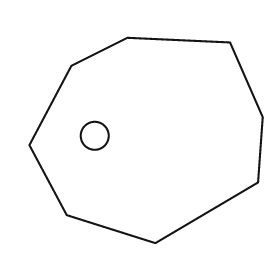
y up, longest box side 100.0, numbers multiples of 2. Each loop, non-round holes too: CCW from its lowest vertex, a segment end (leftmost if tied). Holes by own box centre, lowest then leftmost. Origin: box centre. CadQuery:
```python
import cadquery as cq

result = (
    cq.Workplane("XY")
    .moveTo(4.0, -44.0)
    .lineTo(48.0, -18.0)
    .lineTo(50.0, 10.0)
    .lineTo(36.0, 42.0)
    .lineTo(-8.0, 44.0)
    .lineTo(-32.0, 32.0)
    .lineTo(-50.0, -2.0)
    .lineTo(-34.0, -32.0)
    .close()
    .moveTo(-22.0, 2.0)
    .circle(6.0)
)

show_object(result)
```